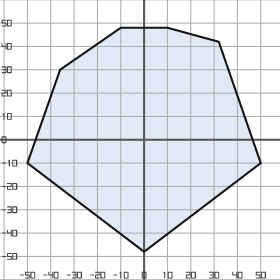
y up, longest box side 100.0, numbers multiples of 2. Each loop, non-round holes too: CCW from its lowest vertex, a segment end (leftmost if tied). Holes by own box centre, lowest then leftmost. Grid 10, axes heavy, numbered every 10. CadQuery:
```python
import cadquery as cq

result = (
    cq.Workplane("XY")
    .moveTo(0.0, -48.0)
    .lineTo(50.0, -10.0)
    .lineTo(32.0, 42.0)
    .lineTo(10.0, 48.0)
    .lineTo(-10.0, 48.0)
    .lineTo(-36.0, 30.0)
    .lineTo(-50.0, -10.0)
    .close()
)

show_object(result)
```